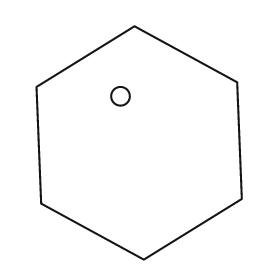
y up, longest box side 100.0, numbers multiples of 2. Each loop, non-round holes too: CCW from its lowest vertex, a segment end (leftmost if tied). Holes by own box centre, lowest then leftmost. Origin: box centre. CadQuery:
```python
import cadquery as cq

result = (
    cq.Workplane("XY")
    .moveTo(2.0, -50.0)
    .lineTo(44.0, -24.0)
    .lineTo(42.0, 26.0)
    .lineTo(-2.0, 50.0)
    .lineTo(-44.0, 24.0)
    .lineTo(-42.0, -26.0)
    .close()
    .moveTo(-8.0, 20.0)
    .circle(4.0)
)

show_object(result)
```